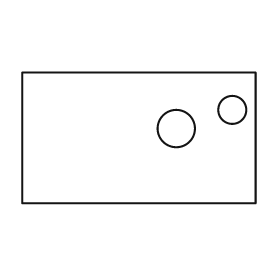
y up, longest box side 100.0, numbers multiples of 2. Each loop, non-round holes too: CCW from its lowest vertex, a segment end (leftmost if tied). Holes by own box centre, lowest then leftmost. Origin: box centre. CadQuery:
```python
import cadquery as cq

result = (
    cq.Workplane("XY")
    .moveTo(-50.0, -28.0)
    .lineTo(50.0, -28.0)
    .lineTo(50.0, 28.0)
    .lineTo(-50.0, 28.0)
    .close()
    .moveTo(16.0, 4.0)
    .circle(8.0)
    .moveTo(40.0, 12.0)
    .circle(6.0)
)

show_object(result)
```